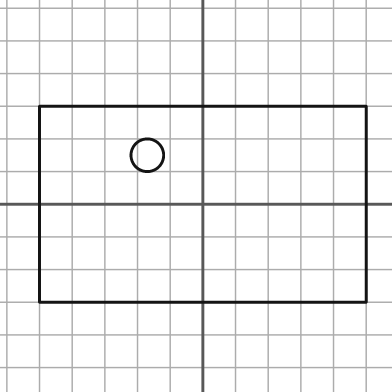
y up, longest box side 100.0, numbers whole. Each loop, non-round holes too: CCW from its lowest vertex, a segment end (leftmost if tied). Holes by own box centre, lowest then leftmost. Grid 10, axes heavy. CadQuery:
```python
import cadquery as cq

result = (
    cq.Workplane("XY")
    .moveTo(-50.0, -30.0)
    .lineTo(50.0, -30.0)
    .lineTo(50.0, 30.0)
    .lineTo(-50.0, 30.0)
    .close()
    .moveTo(-17.0, 15.0)
    .circle(5.0)
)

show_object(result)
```